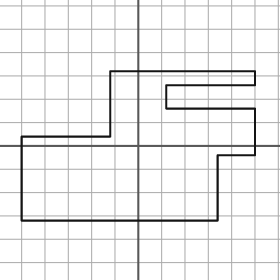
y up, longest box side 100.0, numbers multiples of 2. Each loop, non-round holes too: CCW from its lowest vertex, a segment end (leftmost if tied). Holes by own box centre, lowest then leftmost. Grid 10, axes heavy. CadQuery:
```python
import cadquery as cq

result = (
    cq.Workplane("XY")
    .moveTo(-50.0, -32.0)
    .lineTo(34.0, -32.0)
    .lineTo(34.0, -4.0)
    .lineTo(50.0, -4.0)
    .lineTo(50.0, 16.0)
    .lineTo(12.0, 16.0)
    .lineTo(12.0, 26.0)
    .lineTo(50.0, 26.0)
    .lineTo(50.0, 32.0)
    .lineTo(-12.0, 32.0)
    .lineTo(-12.0, 4.0)
    .lineTo(-50.0, 4.0)
    .close()
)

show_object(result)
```